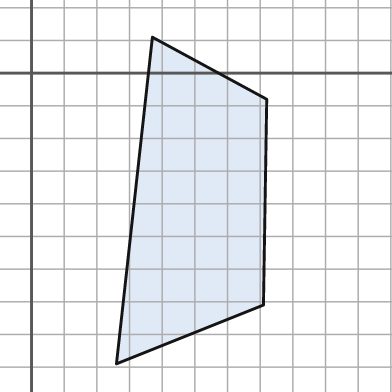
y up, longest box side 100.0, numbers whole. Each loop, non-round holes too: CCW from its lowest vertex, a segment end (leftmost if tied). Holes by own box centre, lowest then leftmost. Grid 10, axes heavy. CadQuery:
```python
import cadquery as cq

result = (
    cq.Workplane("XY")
    .moveTo(26.0, -89.0)
    .lineTo(71.0, -71.0)
    .lineTo(72.0, -8.0)
    .lineTo(37.0, 11.0)
    .close()
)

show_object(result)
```